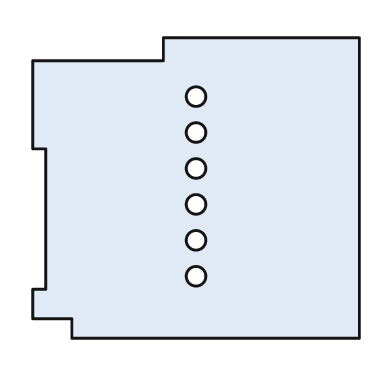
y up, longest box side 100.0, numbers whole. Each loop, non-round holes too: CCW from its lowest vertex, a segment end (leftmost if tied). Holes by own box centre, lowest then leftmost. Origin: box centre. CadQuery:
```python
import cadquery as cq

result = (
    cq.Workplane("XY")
    .moveTo(-38.0, -46.0)
    .lineTo(50.0, -46.0)
    .lineTo(50.0, 46.0)
    .lineTo(-10.0, 46.0)
    .lineTo(-10.0, 39.0)
    .lineTo(-50.0, 39.0)
    .lineTo(-50.0, 12.0)
    .lineTo(-46.0, 12.0)
    .lineTo(-46.0, -31.0)
    .lineTo(-50.0, -31.0)
    .lineTo(-50.0, -40.0)
    .lineTo(-38.0, -40.0)
    .close()
    .moveTo(0.0, -27.0)
    .circle(3.0)
    .moveTo(0.0, -16.0)
    .circle(3.0)
    .moveTo(0.0, -5.0)
    .circle(3.0)
    .moveTo(0.0, 6.0)
    .circle(3.0)
    .moveTo(0.0, 17.0)
    .circle(3.0)
    .moveTo(0.0, 28.0)
    .circle(3.0)
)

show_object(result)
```